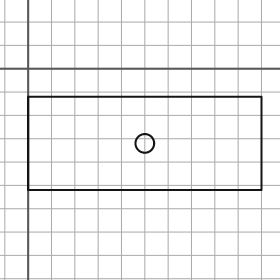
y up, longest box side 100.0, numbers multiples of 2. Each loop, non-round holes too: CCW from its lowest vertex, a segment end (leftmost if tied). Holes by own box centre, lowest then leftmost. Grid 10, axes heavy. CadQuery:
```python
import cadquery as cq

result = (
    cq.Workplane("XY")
    .moveTo(0.0, -52.0)
    .lineTo(100.0, -52.0)
    .lineTo(100.0, -12.0)
    .lineTo(0.0, -12.0)
    .close()
    .moveTo(50.0, -32.0)
    .circle(4.0)
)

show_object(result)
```